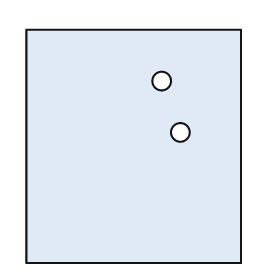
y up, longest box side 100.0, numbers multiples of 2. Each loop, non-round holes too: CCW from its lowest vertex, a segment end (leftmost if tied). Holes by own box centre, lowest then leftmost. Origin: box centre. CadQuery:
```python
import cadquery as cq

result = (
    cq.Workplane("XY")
    .moveTo(-46.0, -50.0)
    .lineTo(46.0, -50.0)
    .lineTo(46.0, 50.0)
    .lineTo(-46.0, 50.0)
    .close()
    .moveTo(20.0, 6.0)
    .circle(4.0)
    .moveTo(12.0, 28.0)
    .circle(4.0)
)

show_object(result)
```